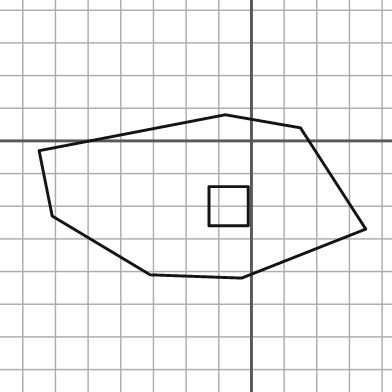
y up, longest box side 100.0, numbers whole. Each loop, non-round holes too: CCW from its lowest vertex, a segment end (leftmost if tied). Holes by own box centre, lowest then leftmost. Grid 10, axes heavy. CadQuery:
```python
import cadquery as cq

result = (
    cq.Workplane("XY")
    .moveTo(-3.0, -42.0)
    .lineTo(35.0, -27.0)
    .lineTo(15.0, 4.0)
    .lineTo(-8.0, 8.0)
    .lineTo(-65.0, -3.0)
    .lineTo(-61.0, -23.0)
    .lineTo(-31.0, -41.0)
    .close()
    .moveTo(-13.0, -26.0)
    .lineTo(-1.0, -26.0)
    .lineTo(-1.0, -14.0)
    .lineTo(-13.0, -14.0)
    .close()
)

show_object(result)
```